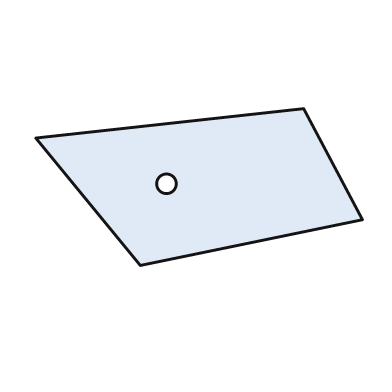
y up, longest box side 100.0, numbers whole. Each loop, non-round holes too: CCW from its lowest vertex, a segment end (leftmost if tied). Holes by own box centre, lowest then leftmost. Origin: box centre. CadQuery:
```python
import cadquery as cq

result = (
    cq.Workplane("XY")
    .moveTo(-18.0, -24.0)
    .lineTo(50.0, -10.0)
    .lineTo(32.0, 24.0)
    .lineTo(-50.0, 15.0)
    .close()
    .moveTo(-10.0, 1.0)
    .circle(3.0)
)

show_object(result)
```